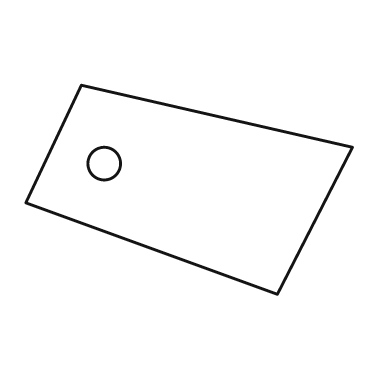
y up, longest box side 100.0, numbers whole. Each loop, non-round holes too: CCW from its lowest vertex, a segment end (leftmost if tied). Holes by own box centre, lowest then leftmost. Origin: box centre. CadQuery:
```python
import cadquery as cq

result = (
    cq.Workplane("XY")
    .moveTo(27.0, -32.0)
    .lineTo(50.0, 13.0)
    .lineTo(-33.0, 32.0)
    .lineTo(-50.0, -4.0)
    .close()
    .moveTo(-26.0, 8.0)
    .circle(5.0)
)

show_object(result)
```